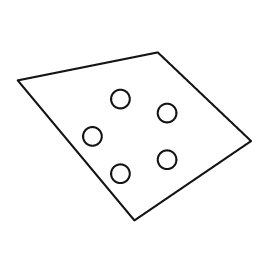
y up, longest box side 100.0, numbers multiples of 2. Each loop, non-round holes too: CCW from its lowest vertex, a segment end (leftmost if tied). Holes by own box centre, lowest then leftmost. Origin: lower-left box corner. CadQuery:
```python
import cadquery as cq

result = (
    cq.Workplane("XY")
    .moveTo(50.0, 0.0)
    .lineTo(100.0, 34.0)
    .lineTo(60.0, 72.0)
    .lineTo(0.0, 60.0)
    .close()
    .moveTo(44.0, 20.0)
    .circle(4.0)
    .moveTo(64.0, 26.0)
    .circle(4.0)
    .moveTo(32.0, 36.0)
    .circle(4.0)
    .moveTo(64.0, 46.0)
    .circle(4.0)
    .moveTo(44.0, 52.0)
    .circle(4.0)
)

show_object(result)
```